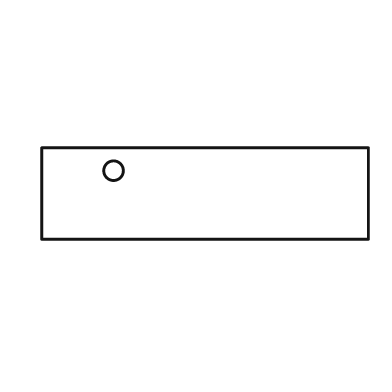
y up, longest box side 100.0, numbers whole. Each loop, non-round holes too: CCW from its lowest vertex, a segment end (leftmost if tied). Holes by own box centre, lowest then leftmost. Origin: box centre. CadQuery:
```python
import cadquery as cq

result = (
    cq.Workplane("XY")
    .moveTo(-50.0, -14.0)
    .lineTo(50.0, -14.0)
    .lineTo(50.0, 14.0)
    .lineTo(-50.0, 14.0)
    .close()
    .moveTo(-28.0, 7.0)
    .circle(3.0)
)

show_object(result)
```